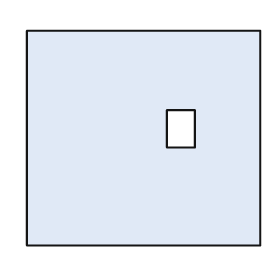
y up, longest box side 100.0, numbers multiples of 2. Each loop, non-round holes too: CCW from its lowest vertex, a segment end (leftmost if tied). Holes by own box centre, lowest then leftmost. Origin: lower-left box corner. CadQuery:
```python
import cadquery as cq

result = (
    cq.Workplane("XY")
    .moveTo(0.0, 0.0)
    .lineTo(100.0, 0.0)
    .lineTo(100.0, 92.0)
    .lineTo(0.0, 92.0)
    .close()
    .moveTo(60.0, 42.0)
    .lineTo(72.0, 42.0)
    .lineTo(72.0, 58.0)
    .lineTo(60.0, 58.0)
    .close()
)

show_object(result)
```